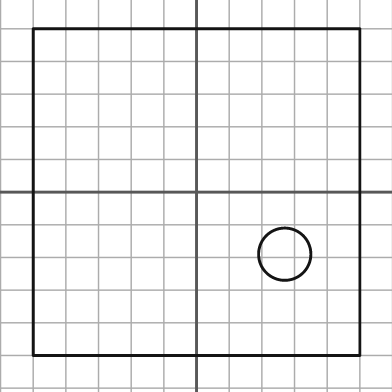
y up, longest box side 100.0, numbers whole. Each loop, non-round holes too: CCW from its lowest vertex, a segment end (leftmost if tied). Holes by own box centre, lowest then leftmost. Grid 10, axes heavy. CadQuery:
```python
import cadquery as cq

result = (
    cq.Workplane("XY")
    .moveTo(-50.0, -50.0)
    .lineTo(50.0, -50.0)
    .lineTo(50.0, 50.0)
    .lineTo(-50.0, 50.0)
    .close()
    .moveTo(27.0, -19.0)
    .circle(8.0)
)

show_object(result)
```